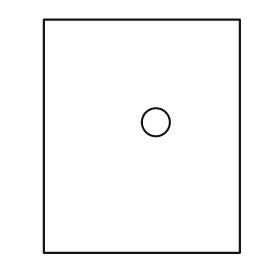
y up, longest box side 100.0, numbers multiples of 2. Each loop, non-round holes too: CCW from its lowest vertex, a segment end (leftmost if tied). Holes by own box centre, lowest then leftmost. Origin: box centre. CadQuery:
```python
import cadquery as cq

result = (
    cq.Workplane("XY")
    .moveTo(-42.0, -50.0)
    .lineTo(42.0, -50.0)
    .lineTo(42.0, 50.0)
    .lineTo(-42.0, 50.0)
    .close()
    .moveTo(6.0, 6.0)
    .circle(6.0)
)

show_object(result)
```